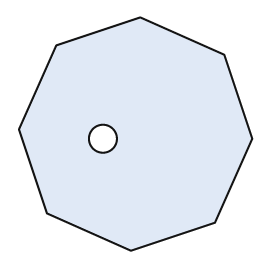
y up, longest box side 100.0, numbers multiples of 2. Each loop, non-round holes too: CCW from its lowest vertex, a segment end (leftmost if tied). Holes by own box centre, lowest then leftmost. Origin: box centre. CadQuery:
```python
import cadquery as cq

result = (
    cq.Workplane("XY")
    .moveTo(-2.0, -50.0)
    .lineTo(34.0, -38.0)
    .lineTo(50.0, -2.0)
    .lineTo(38.0, 34.0)
    .lineTo(2.0, 50.0)
    .lineTo(-34.0, 38.0)
    .lineTo(-50.0, 2.0)
    .lineTo(-38.0, -34.0)
    .close()
    .moveTo(-14.0, -2.0)
    .circle(6.0)
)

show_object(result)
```